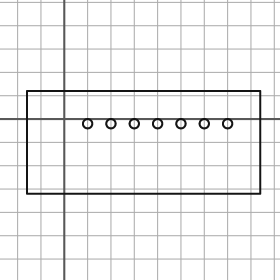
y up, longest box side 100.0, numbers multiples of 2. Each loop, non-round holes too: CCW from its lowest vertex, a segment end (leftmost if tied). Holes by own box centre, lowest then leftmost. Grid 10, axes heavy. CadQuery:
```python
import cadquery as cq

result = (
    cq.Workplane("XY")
    .moveTo(-16.0, -32.0)
    .lineTo(84.0, -32.0)
    .lineTo(84.0, 12.0)
    .lineTo(-16.0, 12.0)
    .close()
    .moveTo(10.0, -2.0)
    .circle(2.0)
    .moveTo(20.0, -2.0)
    .circle(2.0)
    .moveTo(30.0, -2.0)
    .circle(2.0)
    .moveTo(40.0, -2.0)
    .circle(2.0)
    .moveTo(50.0, -2.0)
    .circle(2.0)
    .moveTo(60.0, -2.0)
    .circle(2.0)
    .moveTo(70.0, -2.0)
    .circle(2.0)
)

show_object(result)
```